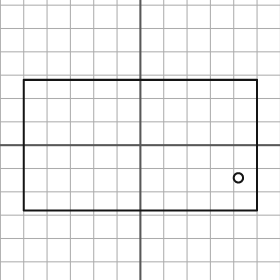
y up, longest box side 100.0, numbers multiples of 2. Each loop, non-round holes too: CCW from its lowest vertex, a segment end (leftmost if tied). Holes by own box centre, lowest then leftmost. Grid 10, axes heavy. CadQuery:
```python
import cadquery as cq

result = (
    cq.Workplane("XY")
    .moveTo(-50.0, -28.0)
    .lineTo(50.0, -28.0)
    .lineTo(50.0, 28.0)
    .lineTo(-50.0, 28.0)
    .close()
    .moveTo(42.0, -14.0)
    .circle(2.0)
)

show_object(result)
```